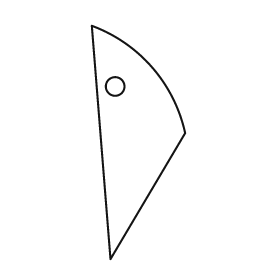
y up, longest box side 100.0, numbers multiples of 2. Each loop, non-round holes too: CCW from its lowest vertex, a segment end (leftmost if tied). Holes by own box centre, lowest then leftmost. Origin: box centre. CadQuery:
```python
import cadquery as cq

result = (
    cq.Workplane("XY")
    .moveTo(-12.0, -50.0)
    .lineTo(20.0, 4.0)
    .threePointArc((6.0, 32.0), (-20.0, 50.0))
    .close()
    .moveTo(-10.0, 24.0)
    .circle(4.0)
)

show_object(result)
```